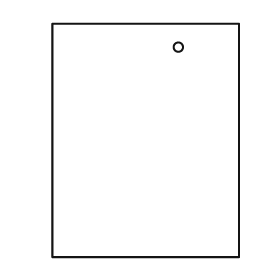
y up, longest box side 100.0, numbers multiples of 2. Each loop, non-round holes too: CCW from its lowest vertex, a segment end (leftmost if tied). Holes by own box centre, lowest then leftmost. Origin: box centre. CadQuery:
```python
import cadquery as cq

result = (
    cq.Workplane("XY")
    .moveTo(-40.0, -50.0)
    .lineTo(40.0, -50.0)
    .lineTo(40.0, 50.0)
    .lineTo(-40.0, 50.0)
    .close()
    .moveTo(14.0, 40.0)
    .circle(2.0)
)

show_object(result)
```